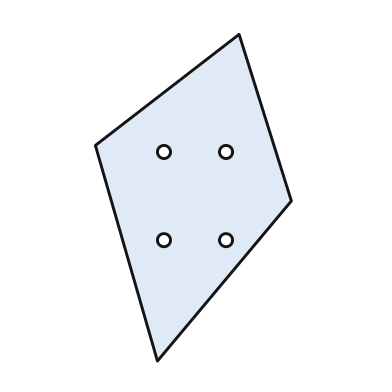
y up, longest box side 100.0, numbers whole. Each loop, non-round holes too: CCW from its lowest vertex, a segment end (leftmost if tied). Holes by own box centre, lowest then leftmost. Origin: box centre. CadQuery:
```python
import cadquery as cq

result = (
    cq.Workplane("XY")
    .moveTo(-11.0, -50.0)
    .lineTo(30.0, -1.0)
    .lineTo(14.0, 50.0)
    .lineTo(-30.0, 16.0)
    .close()
    .moveTo(-9.0, -13.0)
    .circle(2.0)
    .moveTo(10.0, -13.0)
    .circle(2.0)
    .moveTo(-9.0, 14.0)
    .circle(2.0)
    .moveTo(10.0, 14.0)
    .circle(2.0)
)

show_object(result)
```